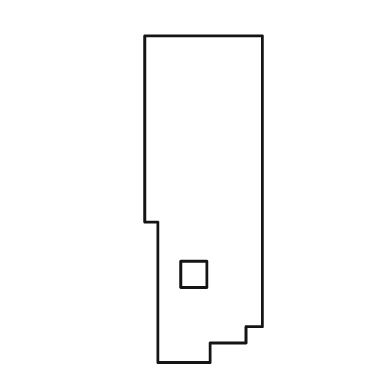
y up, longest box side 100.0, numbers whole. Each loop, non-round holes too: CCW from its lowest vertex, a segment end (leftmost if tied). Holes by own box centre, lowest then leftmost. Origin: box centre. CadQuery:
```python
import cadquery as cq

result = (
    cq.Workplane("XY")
    .moveTo(-14.0, -50.0)
    .lineTo(2.0, -50.0)
    .lineTo(2.0, -44.0)
    .lineTo(13.0, -44.0)
    .lineTo(13.0, -39.0)
    .lineTo(18.0, -39.0)
    .lineTo(18.0, 50.0)
    .lineTo(-18.0, 50.0)
    .lineTo(-18.0, -7.0)
    .lineTo(-14.0, -7.0)
    .close()
    .moveTo(-7.0, -27.0)
    .lineTo(1.0, -27.0)
    .lineTo(1.0, -19.0)
    .lineTo(-7.0, -19.0)
    .close()
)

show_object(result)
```